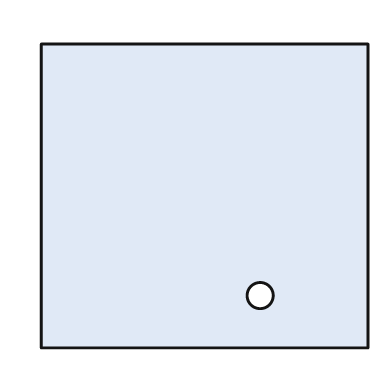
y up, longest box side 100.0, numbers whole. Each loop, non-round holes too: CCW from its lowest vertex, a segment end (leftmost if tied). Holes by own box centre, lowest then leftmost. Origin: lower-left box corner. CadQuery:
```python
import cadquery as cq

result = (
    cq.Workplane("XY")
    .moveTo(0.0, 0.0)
    .lineTo(100.0, 0.0)
    .lineTo(100.0, 93.0)
    .lineTo(0.0, 93.0)
    .close()
    .moveTo(67.0, 16.0)
    .circle(4.0)
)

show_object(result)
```